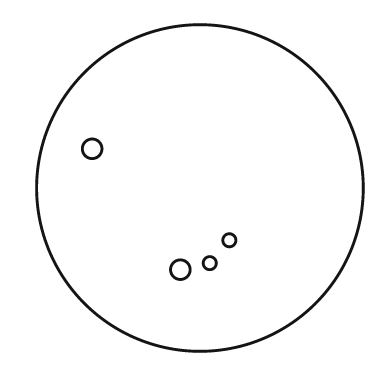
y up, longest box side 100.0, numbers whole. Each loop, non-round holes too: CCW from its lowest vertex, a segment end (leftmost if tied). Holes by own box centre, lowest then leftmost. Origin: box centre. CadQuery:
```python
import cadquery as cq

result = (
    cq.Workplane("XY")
    .moveTo(0.0, 0.0)
    .circle(50.0)
    .moveTo(-6.0, -25.0)
    .circle(3.0)
    .moveTo(3.0, -23.0)
    .circle(2.0)
    .moveTo(9.0, -16.0)
    .circle(2.0)
    .moveTo(-33.0, 12.0)
    .circle(3.0)
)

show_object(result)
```